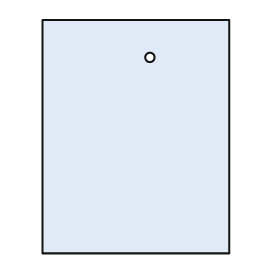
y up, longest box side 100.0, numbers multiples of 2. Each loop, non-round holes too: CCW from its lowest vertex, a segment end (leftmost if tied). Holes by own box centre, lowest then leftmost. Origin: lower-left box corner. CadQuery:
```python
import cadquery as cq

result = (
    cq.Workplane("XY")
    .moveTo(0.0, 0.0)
    .lineTo(80.0, 0.0)
    .lineTo(80.0, 100.0)
    .lineTo(0.0, 100.0)
    .close()
    .moveTo(46.0, 84.0)
    .circle(2.0)
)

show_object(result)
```